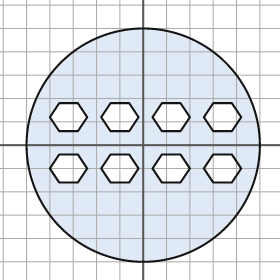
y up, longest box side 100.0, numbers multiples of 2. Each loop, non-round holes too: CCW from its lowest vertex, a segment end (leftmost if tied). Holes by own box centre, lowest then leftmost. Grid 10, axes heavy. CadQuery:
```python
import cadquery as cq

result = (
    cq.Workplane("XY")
    .moveTo(0.0, 0.0)
    .circle(50.0)
    .moveTo(-36.0, -16.0)
    .lineTo(-28.0, -16.0)
    .lineTo(-24.0, -10.0)
    .lineTo(-28.0, -4.0)
    .lineTo(-36.0, -4.0)
    .lineTo(-40.0, -10.0)
    .close()
    .moveTo(-14.0, -16.0)
    .lineTo(-6.0, -16.0)
    .lineTo(-2.0, -10.0)
    .lineTo(-6.0, -4.0)
    .lineTo(-14.0, -4.0)
    .lineTo(-18.0, -10.0)
    .close()
    .moveTo(8.0, -16.0)
    .lineTo(16.0, -16.0)
    .lineTo(20.0, -10.0)
    .lineTo(16.0, -4.0)
    .lineTo(8.0, -4.0)
    .lineTo(4.0, -10.0)
    .close()
    .moveTo(30.0, -16.0)
    .lineTo(38.0, -16.0)
    .lineTo(42.0, -10.0)
    .lineTo(38.0, -4.0)
    .lineTo(30.0, -4.0)
    .lineTo(26.0, -10.0)
    .close()
    .moveTo(-36.0, 6.0)
    .lineTo(-28.0, 6.0)
    .lineTo(-24.0, 12.0)
    .lineTo(-28.0, 18.0)
    .lineTo(-36.0, 18.0)
    .lineTo(-40.0, 12.0)
    .close()
    .moveTo(-14.0, 6.0)
    .lineTo(-6.0, 6.0)
    .lineTo(-2.0, 12.0)
    .lineTo(-6.0, 18.0)
    .lineTo(-14.0, 18.0)
    .lineTo(-18.0, 12.0)
    .close()
    .moveTo(8.0, 6.0)
    .lineTo(16.0, 6.0)
    .lineTo(20.0, 12.0)
    .lineTo(16.0, 18.0)
    .lineTo(8.0, 18.0)
    .lineTo(4.0, 12.0)
    .close()
    .moveTo(30.0, 6.0)
    .lineTo(38.0, 6.0)
    .lineTo(42.0, 12.0)
    .lineTo(38.0, 18.0)
    .lineTo(30.0, 18.0)
    .lineTo(26.0, 12.0)
    .close()
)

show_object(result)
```